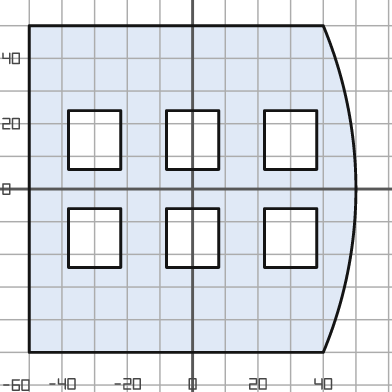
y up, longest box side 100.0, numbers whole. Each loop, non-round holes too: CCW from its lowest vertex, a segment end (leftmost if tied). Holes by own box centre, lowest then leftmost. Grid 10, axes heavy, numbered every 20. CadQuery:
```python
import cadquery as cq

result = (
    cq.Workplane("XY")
    .moveTo(-50.0, -50.0)
    .lineTo(40.0, -50.0)
    .threePointArc((50.0, 0.0), (40.0, 50.0))
    .lineTo(-50.0, 50.0)
    .close()
    .moveTo(-38.0, -24.0)
    .lineTo(-22.0, -24.0)
    .lineTo(-22.0, -6.0)
    .lineTo(-38.0, -6.0)
    .close()
    .moveTo(-8.0, -24.0)
    .lineTo(8.0, -24.0)
    .lineTo(8.0, -6.0)
    .lineTo(-8.0, -6.0)
    .close()
    .moveTo(22.0, -24.0)
    .lineTo(38.0, -24.0)
    .lineTo(38.0, -6.0)
    .lineTo(22.0, -6.0)
    .close()
    .moveTo(-38.0, 6.0)
    .lineTo(-22.0, 6.0)
    .lineTo(-22.0, 24.0)
    .lineTo(-38.0, 24.0)
    .close()
    .moveTo(-8.0, 6.0)
    .lineTo(8.0, 6.0)
    .lineTo(8.0, 24.0)
    .lineTo(-8.0, 24.0)
    .close()
    .moveTo(22.0, 6.0)
    .lineTo(38.0, 6.0)
    .lineTo(38.0, 24.0)
    .lineTo(22.0, 24.0)
    .close()
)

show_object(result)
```